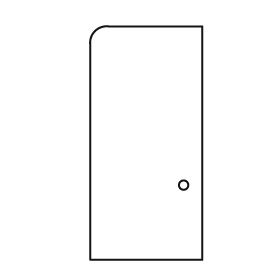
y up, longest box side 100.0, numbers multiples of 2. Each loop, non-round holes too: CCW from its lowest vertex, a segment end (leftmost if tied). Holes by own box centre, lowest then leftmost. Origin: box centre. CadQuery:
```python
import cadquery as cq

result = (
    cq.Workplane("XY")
    .moveTo(-24.0, -50.0)
    .lineTo(24.0, -50.0)
    .lineTo(24.0, 50.0)
    .lineTo(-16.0, 50.0)
    .threePointArc((-22.0, 48.0), (-24.0, 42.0))
    .close()
    .moveTo(16.0, -18.0)
    .circle(2.0)
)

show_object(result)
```